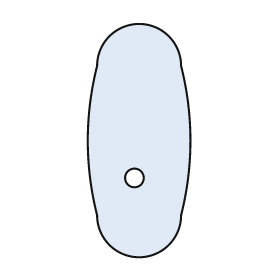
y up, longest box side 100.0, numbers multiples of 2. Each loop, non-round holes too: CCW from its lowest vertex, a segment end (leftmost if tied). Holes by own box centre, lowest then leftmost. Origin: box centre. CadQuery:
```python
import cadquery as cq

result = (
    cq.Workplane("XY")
    .moveTo(-18.0, -32.0)
    .threePointArc((0.0, -50.0), (18.0, -32.0))
    .threePointArc((22.0, 0.0), (18.0, 32.0))
    .threePointArc((0.0, 50.0), (-18.0, 32.0))
    .threePointArc((-22.0, 0.0), (-18.0, -32.0))
    .close()
    .moveTo(-2.0, -16.0)
    .circle(4.0)
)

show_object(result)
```